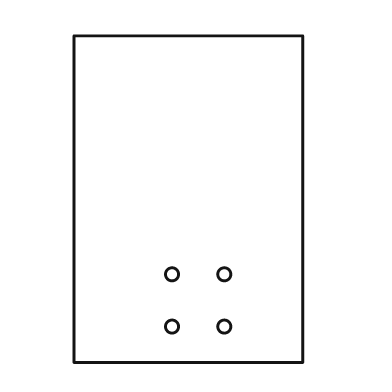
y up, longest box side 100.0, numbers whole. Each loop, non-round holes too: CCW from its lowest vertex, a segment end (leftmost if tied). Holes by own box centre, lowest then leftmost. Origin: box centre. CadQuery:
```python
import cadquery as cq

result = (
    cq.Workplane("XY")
    .moveTo(-35.0, -50.0)
    .lineTo(35.0, -50.0)
    .lineTo(35.0, 50.0)
    .lineTo(-35.0, 50.0)
    .close()
    .moveTo(-5.0, -39.0)
    .circle(2.0)
    .moveTo(11.0, -39.0)
    .circle(2.0)
    .moveTo(-5.0, -23.0)
    .circle(2.0)
    .moveTo(11.0, -23.0)
    .circle(2.0)
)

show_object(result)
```